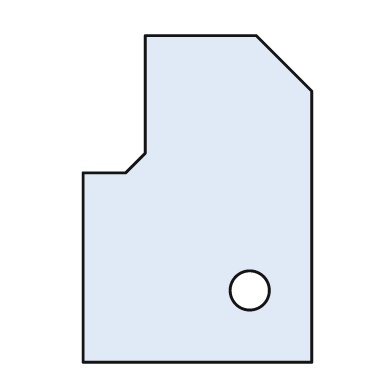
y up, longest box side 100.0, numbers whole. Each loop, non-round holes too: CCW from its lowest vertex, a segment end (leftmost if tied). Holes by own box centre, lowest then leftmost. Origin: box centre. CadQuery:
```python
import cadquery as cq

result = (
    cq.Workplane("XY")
    .moveTo(-35.0, -50.0)
    .lineTo(35.0, -50.0)
    .lineTo(35.0, 33.0)
    .lineTo(18.0, 50.0)
    .lineTo(-16.0, 50.0)
    .lineTo(-16.0, 14.0)
    .lineTo(-22.0, 8.0)
    .lineTo(-35.0, 8.0)
    .close()
    .moveTo(16.0, -28.0)
    .circle(6.0)
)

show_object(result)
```